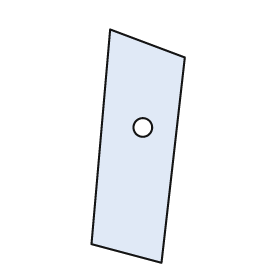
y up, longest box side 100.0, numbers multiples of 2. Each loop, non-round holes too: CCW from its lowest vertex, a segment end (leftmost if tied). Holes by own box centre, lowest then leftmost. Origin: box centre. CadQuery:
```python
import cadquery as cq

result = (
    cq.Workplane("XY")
    .moveTo(10.0, -50.0)
    .lineTo(20.0, 38.0)
    .lineTo(-12.0, 50.0)
    .lineTo(-20.0, -42.0)
    .close()
    .moveTo(2.0, 8.0)
    .circle(4.0)
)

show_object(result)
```